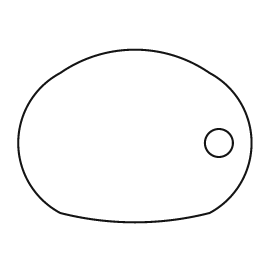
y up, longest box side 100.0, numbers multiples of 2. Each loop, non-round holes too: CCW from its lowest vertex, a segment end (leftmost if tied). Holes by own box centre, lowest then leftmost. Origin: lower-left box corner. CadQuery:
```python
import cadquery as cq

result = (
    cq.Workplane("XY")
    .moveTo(18.0, 4.0)
    .threePointArc((50.0, 0.0), (82.0, 4.0))
    .threePointArc((100.0, 34.0), (82.0, 64.0))
    .threePointArc((50.0, 74.0), (18.0, 64.0))
    .threePointArc((0.0, 34.0), (18.0, 4.0))
    .close()
    .moveTo(86.0, 34.0)
    .circle(6.0)
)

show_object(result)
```